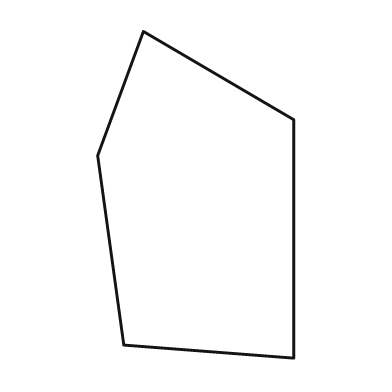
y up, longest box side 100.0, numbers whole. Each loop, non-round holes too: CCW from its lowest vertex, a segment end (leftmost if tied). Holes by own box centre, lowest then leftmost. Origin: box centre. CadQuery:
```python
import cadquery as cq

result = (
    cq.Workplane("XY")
    .moveTo(30.0, -50.0)
    .lineTo(30.0, 23.0)
    .lineTo(-16.0, 50.0)
    .lineTo(-30.0, 12.0)
    .lineTo(-22.0, -46.0)
    .close()
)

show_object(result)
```